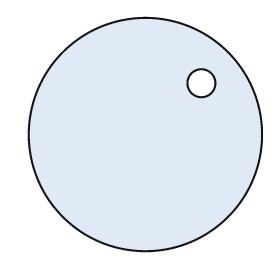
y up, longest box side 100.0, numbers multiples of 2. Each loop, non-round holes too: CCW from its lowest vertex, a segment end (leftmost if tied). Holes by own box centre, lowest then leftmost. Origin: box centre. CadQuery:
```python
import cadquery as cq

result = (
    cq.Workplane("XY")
    .moveTo(0.0, 0.0)
    .circle(50.0)
    .moveTo(24.0, 22.0)
    .circle(6.0)
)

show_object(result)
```